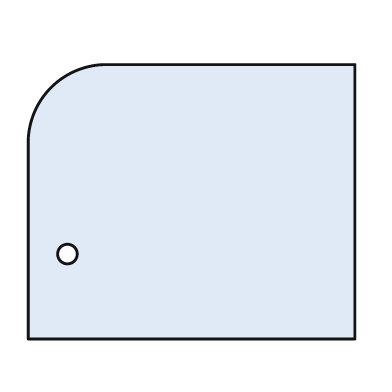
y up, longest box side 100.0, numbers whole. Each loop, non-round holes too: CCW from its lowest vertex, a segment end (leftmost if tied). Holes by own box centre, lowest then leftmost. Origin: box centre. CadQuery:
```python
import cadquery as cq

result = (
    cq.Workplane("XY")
    .moveTo(-50.0, -42.0)
    .lineTo(50.0, -42.0)
    .lineTo(50.0, 42.0)
    .lineTo(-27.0, 42.0)
    .threePointArc((-43.0, 35.0), (-50.0, 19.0))
    .close()
    .moveTo(-38.0, -16.0)
    .circle(3.0)
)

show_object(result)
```